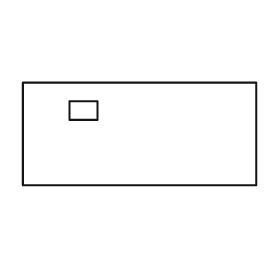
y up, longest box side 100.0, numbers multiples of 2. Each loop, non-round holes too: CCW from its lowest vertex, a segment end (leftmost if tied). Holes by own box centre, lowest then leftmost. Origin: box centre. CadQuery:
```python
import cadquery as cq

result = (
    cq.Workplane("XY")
    .moveTo(-50.0, -22.0)
    .lineTo(50.0, -22.0)
    .lineTo(50.0, 22.0)
    .lineTo(-50.0, 22.0)
    .close()
    .moveTo(-30.0, 6.0)
    .lineTo(-18.0, 6.0)
    .lineTo(-18.0, 14.0)
    .lineTo(-30.0, 14.0)
    .close()
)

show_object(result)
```